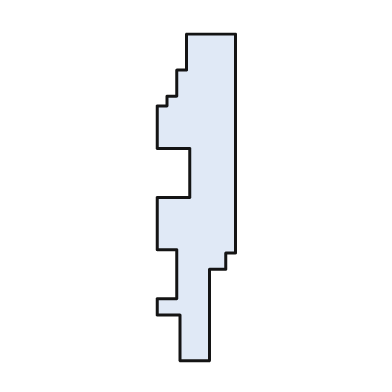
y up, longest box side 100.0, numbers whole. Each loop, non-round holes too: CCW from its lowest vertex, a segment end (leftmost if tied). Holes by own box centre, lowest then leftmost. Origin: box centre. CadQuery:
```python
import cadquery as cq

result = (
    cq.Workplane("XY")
    .moveTo(-5.0, -50.0)
    .lineTo(4.0, -50.0)
    .lineTo(4.0, -22.0)
    .lineTo(9.0, -22.0)
    .lineTo(9.0, -17.0)
    .lineTo(12.0, -17.0)
    .lineTo(12.0, 50.0)
    .lineTo(-3.0, 50.0)
    .lineTo(-3.0, 39.0)
    .lineTo(-6.0, 39.0)
    .lineTo(-6.0, 31.0)
    .lineTo(-9.0, 31.0)
    .lineTo(-9.0, 28.0)
    .lineTo(-12.0, 28.0)
    .lineTo(-12.0, 15.0)
    .lineTo(-2.0, 15.0)
    .lineTo(-2.0, 0.0)
    .lineTo(-12.0, 0.0)
    .lineTo(-12.0, -16.0)
    .lineTo(-6.0, -16.0)
    .lineTo(-6.0, -31.0)
    .lineTo(-12.0, -31.0)
    .lineTo(-12.0, -36.0)
    .lineTo(-5.0, -36.0)
    .close()
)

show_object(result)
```